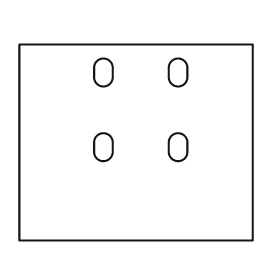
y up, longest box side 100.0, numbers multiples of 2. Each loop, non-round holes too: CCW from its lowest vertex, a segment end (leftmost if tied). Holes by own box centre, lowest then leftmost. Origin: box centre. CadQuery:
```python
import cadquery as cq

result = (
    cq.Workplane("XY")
    .moveTo(-50.0, -42.0)
    .lineTo(50.0, -42.0)
    .lineTo(50.0, 42.0)
    .lineTo(-50.0, 42.0)
    .close()
    .moveTo(-18.0, -4.0)
    .threePointArc((-14.0, -8.0), (-10.0, -4.0))
    .lineTo(-10.0, 0.0)
    .threePointArc((-14.0, 4.0), (-18.0, 0.0))
    .close()
    .moveTo(14.0, -4.0)
    .threePointArc((18.0, -8.0), (22.0, -4.0))
    .lineTo(22.0, 0.0)
    .threePointArc((18.0, 4.0), (14.0, 0.0))
    .close()
    .moveTo(-18.0, 28.0)
    .threePointArc((-14.0, 24.0), (-10.0, 28.0))
    .lineTo(-10.0, 32.0)
    .threePointArc((-14.0, 36.0), (-18.0, 32.0))
    .close()
    .moveTo(14.0, 28.0)
    .threePointArc((18.0, 24.0), (22.0, 28.0))
    .lineTo(22.0, 32.0)
    .threePointArc((18.0, 36.0), (14.0, 32.0))
    .close()
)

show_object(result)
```